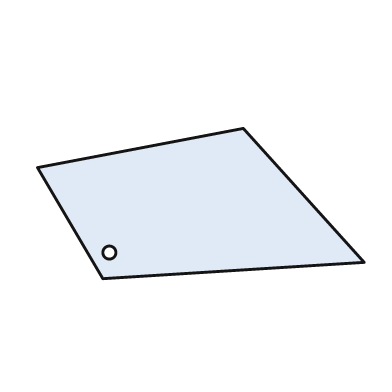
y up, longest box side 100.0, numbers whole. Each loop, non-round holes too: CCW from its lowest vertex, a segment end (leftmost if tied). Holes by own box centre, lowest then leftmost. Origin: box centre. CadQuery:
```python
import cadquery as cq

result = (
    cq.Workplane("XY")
    .moveTo(-30.0, -23.0)
    .lineTo(50.0, -18.0)
    .lineTo(13.0, 23.0)
    .lineTo(-50.0, 11.0)
    .close()
    .moveTo(-28.0, -15.0)
    .circle(2.0)
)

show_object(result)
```